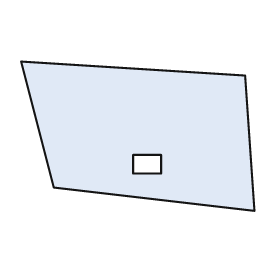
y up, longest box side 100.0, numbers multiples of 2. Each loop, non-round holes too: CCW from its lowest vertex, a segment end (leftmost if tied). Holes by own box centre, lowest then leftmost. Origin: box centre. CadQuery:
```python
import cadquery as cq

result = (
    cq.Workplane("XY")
    .moveTo(50.0, -32.0)
    .lineTo(46.0, 26.0)
    .lineTo(-50.0, 32.0)
    .lineTo(-36.0, -22.0)
    .close()
    .moveTo(-2.0, -16.0)
    .lineTo(10.0, -16.0)
    .lineTo(10.0, -8.0)
    .lineTo(-2.0, -8.0)
    .close()
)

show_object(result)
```